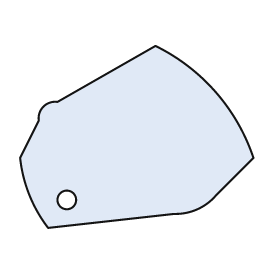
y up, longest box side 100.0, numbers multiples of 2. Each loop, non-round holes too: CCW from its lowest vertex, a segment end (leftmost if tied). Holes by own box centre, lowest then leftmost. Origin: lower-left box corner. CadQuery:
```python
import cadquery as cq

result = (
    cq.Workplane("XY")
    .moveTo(12.0, 0.0)
    .lineTo(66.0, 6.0)
    .threePointArc((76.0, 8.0), (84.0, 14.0))
    .lineTo(100.0, 30.0)
    .threePointArc((84.0, 58.0), (58.0, 78.0))
    .lineTo(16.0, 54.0)
    .threePointArc((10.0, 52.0), (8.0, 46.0))
    .lineTo(0.0, 30.0)
    .threePointArc((4.0, 14.0), (12.0, 0.0))
    .close()
    .moveTo(20.0, 12.0)
    .circle(4.0)
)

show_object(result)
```